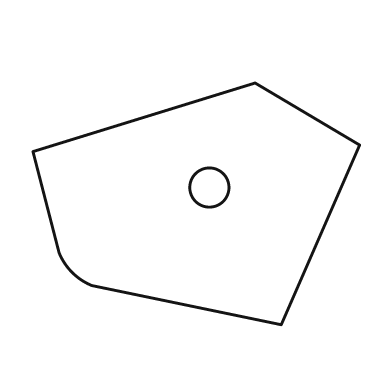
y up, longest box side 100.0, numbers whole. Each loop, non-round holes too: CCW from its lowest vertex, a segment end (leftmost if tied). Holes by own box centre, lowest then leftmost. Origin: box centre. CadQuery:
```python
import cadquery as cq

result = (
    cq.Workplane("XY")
    .moveTo(26.0, -37.0)
    .lineTo(50.0, 18.0)
    .lineTo(18.0, 37.0)
    .lineTo(-50.0, 16.0)
    .lineTo(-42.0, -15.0)
    .threePointArc((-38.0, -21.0), (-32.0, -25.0))
    .close()
    .moveTo(4.0, 5.0)
    .circle(6.0)
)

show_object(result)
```